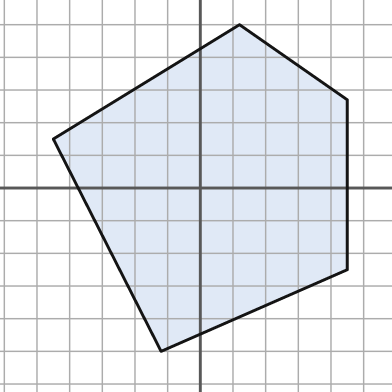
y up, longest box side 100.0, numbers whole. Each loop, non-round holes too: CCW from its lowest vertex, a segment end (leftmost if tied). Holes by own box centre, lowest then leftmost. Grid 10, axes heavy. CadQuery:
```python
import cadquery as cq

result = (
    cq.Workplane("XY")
    .moveTo(-12.0, -50.0)
    .lineTo(45.0, -25.0)
    .lineTo(45.0, 27.0)
    .lineTo(12.0, 50.0)
    .lineTo(-45.0, 15.0)
    .close()
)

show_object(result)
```